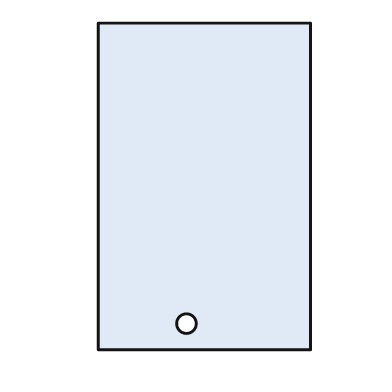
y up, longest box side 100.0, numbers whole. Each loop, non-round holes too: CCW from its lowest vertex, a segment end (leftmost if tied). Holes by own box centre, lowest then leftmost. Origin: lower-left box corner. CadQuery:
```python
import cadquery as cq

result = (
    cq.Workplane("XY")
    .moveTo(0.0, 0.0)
    .lineTo(65.0, 0.0)
    .lineTo(65.0, 100.0)
    .lineTo(0.0, 100.0)
    .close()
    .moveTo(27.0, 8.0)
    .circle(3.0)
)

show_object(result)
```